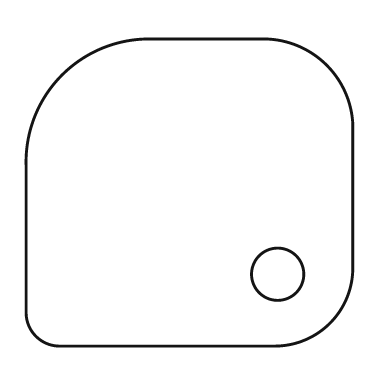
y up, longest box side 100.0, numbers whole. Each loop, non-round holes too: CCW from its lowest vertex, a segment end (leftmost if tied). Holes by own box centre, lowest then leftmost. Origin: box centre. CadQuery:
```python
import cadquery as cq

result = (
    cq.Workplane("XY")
    .moveTo(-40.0, -47.0)
    .lineTo(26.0, -47.0)
    .threePointArc((43.0, -40.0), (50.0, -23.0))
    .lineTo(50.0, 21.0)
    .threePointArc((42.0, 39.0), (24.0, 47.0))
    .lineTo(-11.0, 47.0)
    .threePointArc((-39.0, 36.0), (-50.0, 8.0))
    .lineTo(-50.0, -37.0)
    .threePointArc((-47.0, -44.0), (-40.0, -47.0))
    .close()
    .moveTo(27.0, -25.0)
    .circle(8.0)
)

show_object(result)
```